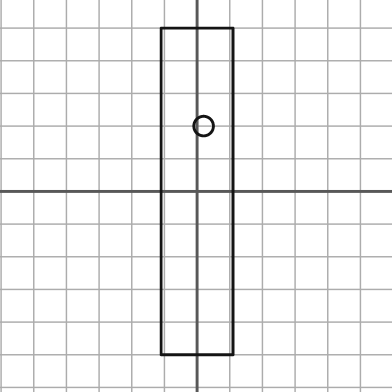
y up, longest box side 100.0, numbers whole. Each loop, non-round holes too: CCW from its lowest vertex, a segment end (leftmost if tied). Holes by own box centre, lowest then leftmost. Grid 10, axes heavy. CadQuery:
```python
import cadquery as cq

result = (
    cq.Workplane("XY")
    .moveTo(-11.0, -50.0)
    .lineTo(11.0, -50.0)
    .lineTo(11.0, 50.0)
    .lineTo(-11.0, 50.0)
    .close()
    .moveTo(2.0, 20.0)
    .circle(3.0)
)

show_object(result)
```